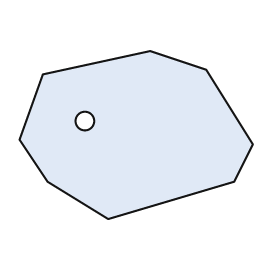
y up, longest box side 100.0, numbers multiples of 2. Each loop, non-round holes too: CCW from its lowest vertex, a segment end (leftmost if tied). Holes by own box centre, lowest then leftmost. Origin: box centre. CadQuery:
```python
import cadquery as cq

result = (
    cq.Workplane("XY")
    .moveTo(-12.0, -36.0)
    .lineTo(42.0, -20.0)
    .lineTo(50.0, -4.0)
    .lineTo(30.0, 28.0)
    .lineTo(6.0, 36.0)
    .lineTo(-40.0, 26.0)
    .lineTo(-50.0, -2.0)
    .lineTo(-38.0, -20.0)
    .close()
    .moveTo(-22.0, 6.0)
    .circle(4.0)
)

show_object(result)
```